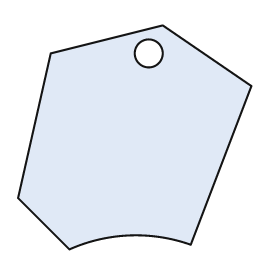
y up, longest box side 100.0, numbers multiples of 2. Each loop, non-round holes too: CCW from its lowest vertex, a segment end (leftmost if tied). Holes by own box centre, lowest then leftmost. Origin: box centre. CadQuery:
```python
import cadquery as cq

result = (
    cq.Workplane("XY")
    .moveTo(-28.0, -48.0)
    .threePointArc((-2.0, -42.0), (24.0, -46.0))
    .lineTo(50.0, 22.0)
    .lineTo(12.0, 48.0)
    .lineTo(-36.0, 36.0)
    .lineTo(-50.0, -26.0)
    .close()
    .moveTo(6.0, 36.0)
    .circle(6.0)
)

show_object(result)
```